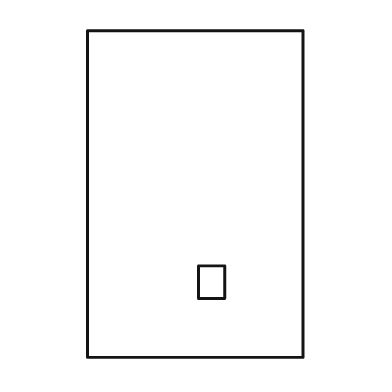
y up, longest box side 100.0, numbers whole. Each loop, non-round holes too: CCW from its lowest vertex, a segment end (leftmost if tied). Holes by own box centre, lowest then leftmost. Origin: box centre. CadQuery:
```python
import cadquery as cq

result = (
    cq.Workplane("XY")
    .moveTo(-33.0, -50.0)
    .lineTo(33.0, -50.0)
    .lineTo(33.0, 50.0)
    .lineTo(-33.0, 50.0)
    .close()
    .moveTo(1.0, -32.0)
    .lineTo(9.0, -32.0)
    .lineTo(9.0, -22.0)
    .lineTo(1.0, -22.0)
    .close()
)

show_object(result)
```